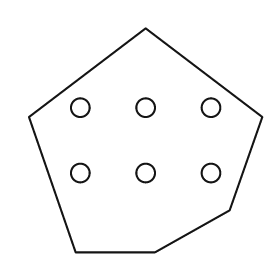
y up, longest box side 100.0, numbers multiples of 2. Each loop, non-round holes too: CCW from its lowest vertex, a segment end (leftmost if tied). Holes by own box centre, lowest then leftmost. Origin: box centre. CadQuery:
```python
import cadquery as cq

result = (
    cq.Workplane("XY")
    .moveTo(-30.0, -48.0)
    .lineTo(4.0, -48.0)
    .lineTo(36.0, -30.0)
    .lineTo(50.0, 10.0)
    .lineTo(0.0, 48.0)
    .lineTo(-50.0, 10.0)
    .close()
    .moveTo(-28.0, -14.0)
    .circle(4.0)
    .moveTo(0.0, -14.0)
    .circle(4.0)
    .moveTo(28.0, -14.0)
    .circle(4.0)
    .moveTo(-28.0, 14.0)
    .circle(4.0)
    .moveTo(0.0, 14.0)
    .circle(4.0)
    .moveTo(28.0, 14.0)
    .circle(4.0)
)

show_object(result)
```